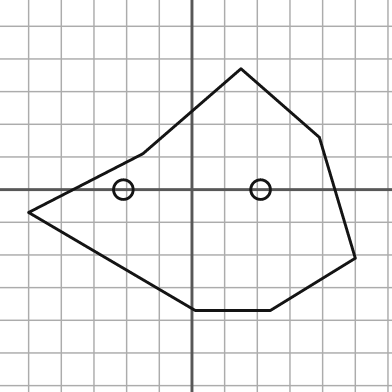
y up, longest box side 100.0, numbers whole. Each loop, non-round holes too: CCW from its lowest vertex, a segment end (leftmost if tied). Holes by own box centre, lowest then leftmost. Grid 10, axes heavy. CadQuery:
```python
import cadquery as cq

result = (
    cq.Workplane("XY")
    .moveTo(1.0, -37.0)
    .lineTo(24.0, -37.0)
    .lineTo(50.0, -21.0)
    .lineTo(39.0, 16.0)
    .lineTo(15.0, 37.0)
    .lineTo(-15.0, 11.0)
    .lineTo(-50.0, -7.0)
    .close()
    .moveTo(-21.0, 0.0)
    .circle(3.0)
    .moveTo(21.0, 0.0)
    .circle(3.0)
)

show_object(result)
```